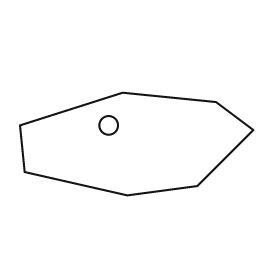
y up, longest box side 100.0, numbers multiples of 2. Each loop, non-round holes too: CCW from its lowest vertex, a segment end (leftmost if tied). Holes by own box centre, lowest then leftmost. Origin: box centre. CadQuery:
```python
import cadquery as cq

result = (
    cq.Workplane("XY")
    .moveTo(-4.0, -22.0)
    .lineTo(26.0, -18.0)
    .lineTo(50.0, 6.0)
    .lineTo(34.0, 18.0)
    .lineTo(-6.0, 22.0)
    .lineTo(-50.0, 8.0)
    .lineTo(-48.0, -12.0)
    .close()
    .moveTo(-12.0, 8.0)
    .circle(4.0)
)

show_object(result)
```